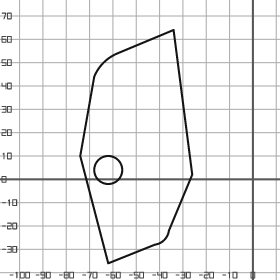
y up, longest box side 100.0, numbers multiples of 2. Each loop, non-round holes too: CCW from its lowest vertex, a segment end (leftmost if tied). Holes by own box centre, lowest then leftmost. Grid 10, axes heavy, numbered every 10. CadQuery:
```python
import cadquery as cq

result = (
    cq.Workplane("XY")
    .moveTo(-62.0, -36.0)
    .lineTo(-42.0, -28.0)
    .threePointArc((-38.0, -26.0), (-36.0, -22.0))
    .lineTo(-26.0, 2.0)
    .lineTo(-34.0, 64.0)
    .lineTo(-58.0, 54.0)
    .threePointArc((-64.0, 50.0), (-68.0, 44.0))
    .lineTo(-74.0, 10.0)
    .close()
    .moveTo(-62.0, 4.0)
    .circle(6.0)
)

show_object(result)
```